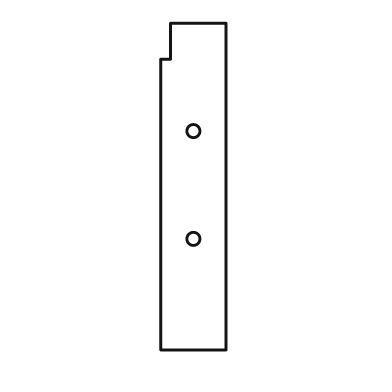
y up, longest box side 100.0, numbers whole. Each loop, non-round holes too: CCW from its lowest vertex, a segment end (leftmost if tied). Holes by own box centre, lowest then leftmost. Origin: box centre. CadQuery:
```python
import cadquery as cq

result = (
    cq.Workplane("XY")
    .moveTo(-10.0, -50.0)
    .lineTo(10.0, -50.0)
    .lineTo(10.0, 50.0)
    .lineTo(-7.0, 50.0)
    .lineTo(-7.0, 39.0)
    .lineTo(-10.0, 39.0)
    .close()
    .moveTo(0.0, -16.0)
    .circle(2.0)
    .moveTo(0.0, 17.0)
    .circle(2.0)
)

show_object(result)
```